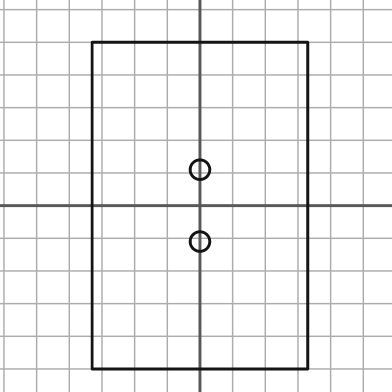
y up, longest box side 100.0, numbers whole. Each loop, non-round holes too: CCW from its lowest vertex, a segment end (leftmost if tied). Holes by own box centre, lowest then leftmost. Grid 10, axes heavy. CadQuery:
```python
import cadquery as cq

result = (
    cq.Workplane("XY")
    .moveTo(-33.0, -50.0)
    .lineTo(33.0, -50.0)
    .lineTo(33.0, 50.0)
    .lineTo(-33.0, 50.0)
    .close()
    .moveTo(0.0, -11.0)
    .circle(3.0)
    .moveTo(0.0, 11.0)
    .circle(3.0)
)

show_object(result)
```